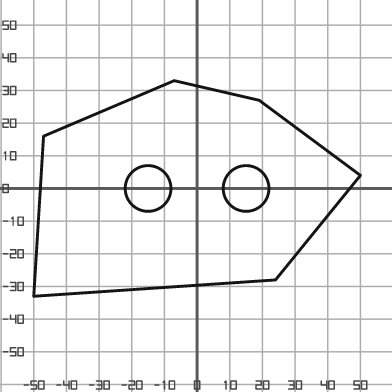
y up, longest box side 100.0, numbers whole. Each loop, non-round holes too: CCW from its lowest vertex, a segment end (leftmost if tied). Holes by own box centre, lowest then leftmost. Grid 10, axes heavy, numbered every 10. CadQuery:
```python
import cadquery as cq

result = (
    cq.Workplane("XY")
    .moveTo(-50.0, -33.0)
    .lineTo(24.0, -28.0)
    .lineTo(50.0, 4.0)
    .lineTo(19.0, 27.0)
    .lineTo(-7.0, 33.0)
    .lineTo(-47.0, 16.0)
    .close()
    .moveTo(-15.0, 0.0)
    .circle(7.0)
    .moveTo(15.0, 0.0)
    .circle(7.0)
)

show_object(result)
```